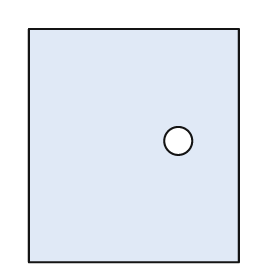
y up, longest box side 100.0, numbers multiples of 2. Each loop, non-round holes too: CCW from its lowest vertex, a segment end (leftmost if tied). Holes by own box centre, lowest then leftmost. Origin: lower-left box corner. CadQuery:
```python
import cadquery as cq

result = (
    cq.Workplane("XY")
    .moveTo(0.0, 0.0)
    .lineTo(90.0, 0.0)
    .lineTo(90.0, 100.0)
    .lineTo(0.0, 100.0)
    .close()
    .moveTo(64.0, 52.0)
    .circle(6.0)
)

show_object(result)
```